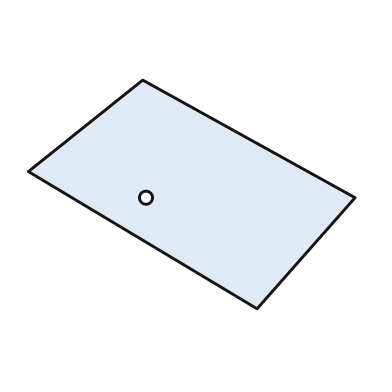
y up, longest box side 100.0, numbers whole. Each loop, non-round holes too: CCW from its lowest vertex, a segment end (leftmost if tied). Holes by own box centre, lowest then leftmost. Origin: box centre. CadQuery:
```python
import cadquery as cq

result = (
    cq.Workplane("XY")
    .moveTo(20.0, -35.0)
    .lineTo(50.0, -1.0)
    .lineTo(-15.0, 35.0)
    .lineTo(-50.0, 7.0)
    .close()
    .moveTo(-14.0, -1.0)
    .circle(2.0)
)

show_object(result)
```